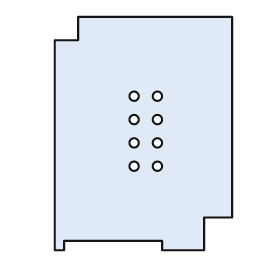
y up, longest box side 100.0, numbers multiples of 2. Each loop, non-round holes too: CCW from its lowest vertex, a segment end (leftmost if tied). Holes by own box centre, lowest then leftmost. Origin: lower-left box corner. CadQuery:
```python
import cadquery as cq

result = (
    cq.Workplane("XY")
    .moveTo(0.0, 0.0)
    .lineTo(4.0, 0.0)
    .lineTo(4.0, 4.0)
    .lineTo(46.0, 4.0)
    .lineTo(46.0, 0.0)
    .lineTo(64.0, 0.0)
    .lineTo(64.0, 14.0)
    .lineTo(76.0, 14.0)
    .lineTo(76.0, 100.0)
    .lineTo(10.0, 100.0)
    .lineTo(10.0, 90.0)
    .lineTo(0.0, 90.0)
    .close()
    .moveTo(34.0, 36.0)
    .circle(2.0)
    .moveTo(44.0, 36.0)
    .circle(2.0)
    .moveTo(34.0, 46.0)
    .circle(2.0)
    .moveTo(44.0, 46.0)
    .circle(2.0)
    .moveTo(34.0, 56.0)
    .circle(2.0)
    .moveTo(44.0, 56.0)
    .circle(2.0)
    .moveTo(34.0, 66.0)
    .circle(2.0)
    .moveTo(44.0, 66.0)
    .circle(2.0)
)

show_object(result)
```